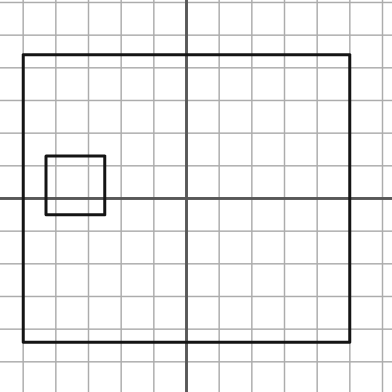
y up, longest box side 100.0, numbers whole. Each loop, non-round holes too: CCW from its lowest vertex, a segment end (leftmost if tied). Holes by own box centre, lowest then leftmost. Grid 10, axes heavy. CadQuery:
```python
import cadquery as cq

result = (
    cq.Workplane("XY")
    .moveTo(-50.0, -44.0)
    .lineTo(50.0, -44.0)
    .lineTo(50.0, 44.0)
    .lineTo(-50.0, 44.0)
    .close()
    .moveTo(-43.0, -5.0)
    .lineTo(-25.0, -5.0)
    .lineTo(-25.0, 13.0)
    .lineTo(-43.0, 13.0)
    .close()
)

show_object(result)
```